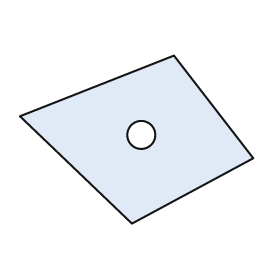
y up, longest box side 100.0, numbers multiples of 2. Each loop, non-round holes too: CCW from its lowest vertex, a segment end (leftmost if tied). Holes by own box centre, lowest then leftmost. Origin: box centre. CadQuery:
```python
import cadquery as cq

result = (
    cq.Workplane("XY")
    .moveTo(-2.0, -36.0)
    .lineTo(50.0, -8.0)
    .lineTo(16.0, 36.0)
    .lineTo(-50.0, 10.0)
    .close()
    .moveTo(2.0, 2.0)
    .circle(6.0)
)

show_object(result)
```